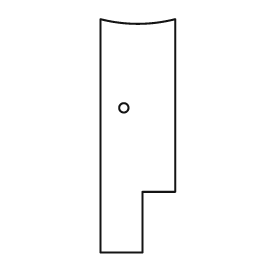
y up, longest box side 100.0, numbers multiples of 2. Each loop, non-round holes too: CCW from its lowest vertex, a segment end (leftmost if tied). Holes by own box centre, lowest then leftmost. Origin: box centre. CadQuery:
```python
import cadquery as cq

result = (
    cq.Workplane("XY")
    .moveTo(-16.0, -50.0)
    .lineTo(2.0, -50.0)
    .lineTo(2.0, -24.0)
    .lineTo(16.0, -24.0)
    .lineTo(16.0, 50.0)
    .threePointArc((0.0, 48.0), (-16.0, 50.0))
    .close()
    .moveTo(-6.0, 12.0)
    .circle(2.0)
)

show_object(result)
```